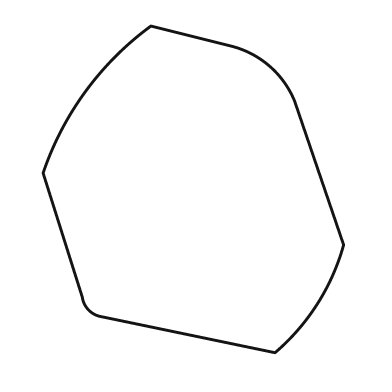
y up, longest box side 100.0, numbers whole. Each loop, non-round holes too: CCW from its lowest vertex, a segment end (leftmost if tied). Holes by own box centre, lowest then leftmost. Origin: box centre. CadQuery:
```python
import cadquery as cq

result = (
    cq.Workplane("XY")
    .moveTo(25.0, -50.0)
    .threePointArc((38.0, -35.0), (46.0, -17.0))
    .lineTo(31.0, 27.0)
    .threePointArc((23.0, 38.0), (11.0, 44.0))
    .lineTo(-13.0, 50.0)
    .threePointArc((-33.0, 30.0), (-46.0, 5.0))
    .lineTo(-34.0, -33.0)
    .threePointArc((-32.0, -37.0), (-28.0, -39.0))
    .close()
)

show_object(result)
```